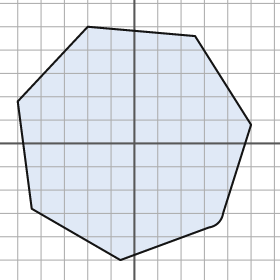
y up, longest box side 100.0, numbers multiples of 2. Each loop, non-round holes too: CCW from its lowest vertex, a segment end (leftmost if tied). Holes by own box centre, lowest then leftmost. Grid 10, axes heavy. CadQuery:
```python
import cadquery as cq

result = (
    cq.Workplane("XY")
    .moveTo(-6.0, -50.0)
    .lineTo(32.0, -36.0)
    .threePointArc((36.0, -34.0), (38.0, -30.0))
    .lineTo(50.0, 8.0)
    .lineTo(26.0, 46.0)
    .lineTo(-20.0, 50.0)
    .lineTo(-50.0, 18.0)
    .lineTo(-44.0, -28.0)
    .close()
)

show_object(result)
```